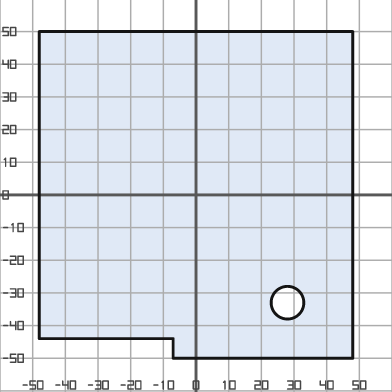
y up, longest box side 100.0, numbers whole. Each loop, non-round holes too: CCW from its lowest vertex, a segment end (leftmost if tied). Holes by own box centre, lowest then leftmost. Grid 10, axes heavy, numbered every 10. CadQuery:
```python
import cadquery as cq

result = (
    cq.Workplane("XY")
    .moveTo(-7.0, -50.0)
    .lineTo(48.0, -50.0)
    .lineTo(48.0, 50.0)
    .lineTo(-48.0, 50.0)
    .lineTo(-48.0, -44.0)
    .lineTo(-7.0, -44.0)
    .close()
    .moveTo(28.0, -33.0)
    .circle(5.0)
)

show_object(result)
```